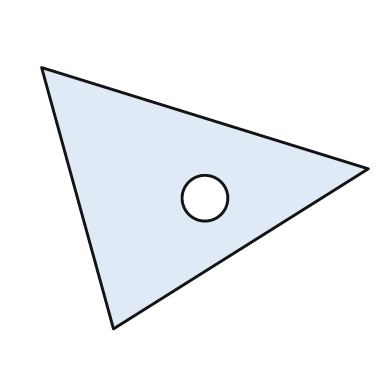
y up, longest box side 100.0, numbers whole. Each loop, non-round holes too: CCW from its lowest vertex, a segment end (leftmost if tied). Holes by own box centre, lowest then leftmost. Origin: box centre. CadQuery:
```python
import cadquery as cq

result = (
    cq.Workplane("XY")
    .moveTo(-28.0, -40.0)
    .lineTo(50.0, 9.0)
    .lineTo(-50.0, 40.0)
    .close()
    .moveTo(0.0, 0.0)
    .circle(7.0)
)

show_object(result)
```